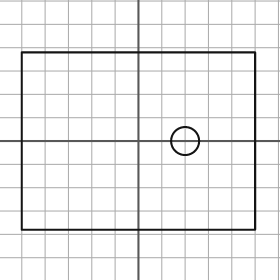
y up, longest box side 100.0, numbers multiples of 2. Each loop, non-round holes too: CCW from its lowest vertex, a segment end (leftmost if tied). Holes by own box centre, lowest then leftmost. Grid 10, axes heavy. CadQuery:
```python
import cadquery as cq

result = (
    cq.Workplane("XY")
    .moveTo(-50.0, -38.0)
    .lineTo(50.0, -38.0)
    .lineTo(50.0, 38.0)
    .lineTo(-50.0, 38.0)
    .close()
    .moveTo(20.0, 0.0)
    .circle(6.0)
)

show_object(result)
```